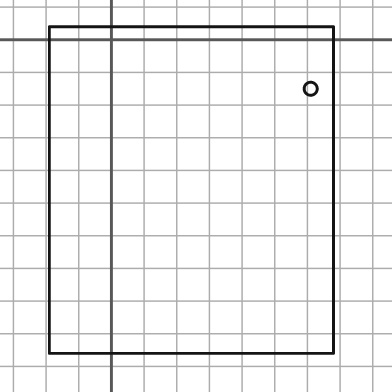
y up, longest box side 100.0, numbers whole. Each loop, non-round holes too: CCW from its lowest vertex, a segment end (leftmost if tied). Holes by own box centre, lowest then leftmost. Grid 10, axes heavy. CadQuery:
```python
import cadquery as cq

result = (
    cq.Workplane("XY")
    .moveTo(-19.0, -96.0)
    .lineTo(68.0, -96.0)
    .lineTo(68.0, 4.0)
    .lineTo(-19.0, 4.0)
    .close()
    .moveTo(61.0, -15.0)
    .circle(2.0)
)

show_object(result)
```